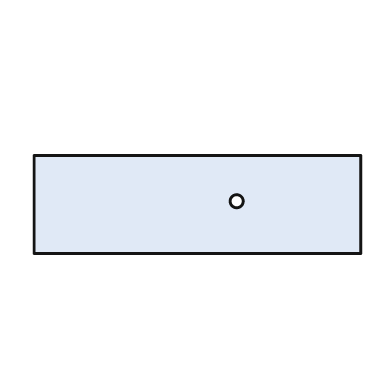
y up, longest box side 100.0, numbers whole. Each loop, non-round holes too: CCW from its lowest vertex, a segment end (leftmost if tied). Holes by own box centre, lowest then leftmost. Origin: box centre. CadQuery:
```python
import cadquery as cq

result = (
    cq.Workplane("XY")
    .moveTo(-50.0, -15.0)
    .lineTo(50.0, -15.0)
    .lineTo(50.0, 15.0)
    .lineTo(-50.0, 15.0)
    .close()
    .moveTo(12.0, 1.0)
    .circle(2.0)
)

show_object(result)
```